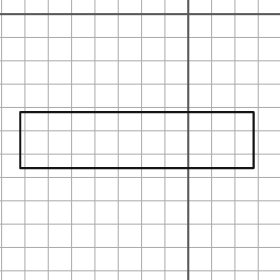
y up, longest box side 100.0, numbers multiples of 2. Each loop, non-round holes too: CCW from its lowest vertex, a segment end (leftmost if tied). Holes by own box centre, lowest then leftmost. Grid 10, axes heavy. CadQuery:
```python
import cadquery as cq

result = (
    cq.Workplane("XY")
    .moveTo(-72.0, -66.0)
    .lineTo(28.0, -66.0)
    .lineTo(28.0, -42.0)
    .lineTo(-72.0, -42.0)
    .close()
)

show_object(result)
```